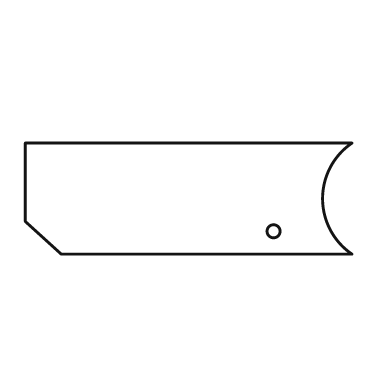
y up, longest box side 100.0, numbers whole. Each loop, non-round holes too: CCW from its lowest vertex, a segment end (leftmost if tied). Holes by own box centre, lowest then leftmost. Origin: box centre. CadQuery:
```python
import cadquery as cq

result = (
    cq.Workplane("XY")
    .moveTo(-39.0, -17.0)
    .lineTo(50.0, -17.0)
    .threePointArc((41.0, 0.0), (50.0, 17.0))
    .lineTo(-50.0, 17.0)
    .lineTo(-50.0, -7.0)
    .close()
    .moveTo(26.0, -10.0)
    .circle(2.0)
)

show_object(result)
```